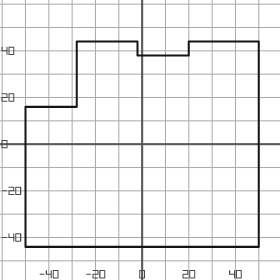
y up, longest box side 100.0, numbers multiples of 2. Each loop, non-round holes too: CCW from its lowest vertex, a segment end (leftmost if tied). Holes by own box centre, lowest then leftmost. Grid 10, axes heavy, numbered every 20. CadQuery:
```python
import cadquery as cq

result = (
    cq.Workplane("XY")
    .moveTo(-50.0, -44.0)
    .lineTo(50.0, -44.0)
    .lineTo(50.0, 44.0)
    .lineTo(20.0, 44.0)
    .lineTo(20.0, 38.0)
    .lineTo(-2.0, 38.0)
    .lineTo(-2.0, 44.0)
    .lineTo(-28.0, 44.0)
    .lineTo(-28.0, 16.0)
    .lineTo(-50.0, 16.0)
    .close()
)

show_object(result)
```